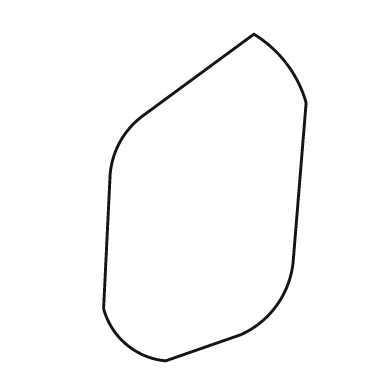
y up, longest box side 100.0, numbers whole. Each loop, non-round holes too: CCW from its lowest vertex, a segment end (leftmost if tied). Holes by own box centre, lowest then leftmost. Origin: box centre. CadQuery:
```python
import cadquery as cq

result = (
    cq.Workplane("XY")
    .moveTo(-12.0, -50.0)
    .lineTo(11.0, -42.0)
    .threePointArc((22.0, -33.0), (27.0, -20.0))
    .lineTo(31.0, 29.0)
    .threePointArc((25.0, 41.0), (15.0, 50.0))
    .lineTo(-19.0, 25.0)
    .threePointArc((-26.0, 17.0), (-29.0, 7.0))
    .lineTo(-31.0, -34.0)
    .threePointArc((-24.0, -45.0), (-12.0, -50.0))
    .close()
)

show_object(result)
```